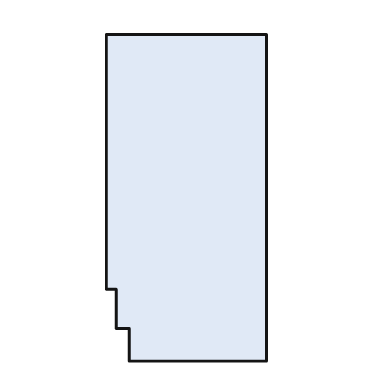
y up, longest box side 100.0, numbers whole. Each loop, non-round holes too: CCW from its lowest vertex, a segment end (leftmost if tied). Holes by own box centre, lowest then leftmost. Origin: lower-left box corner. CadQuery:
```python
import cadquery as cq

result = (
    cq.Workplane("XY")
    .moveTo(7.0, 0.0)
    .lineTo(49.0, 0.0)
    .lineTo(49.0, 100.0)
    .lineTo(0.0, 100.0)
    .lineTo(0.0, 22.0)
    .lineTo(3.0, 22.0)
    .lineTo(3.0, 10.0)
    .lineTo(7.0, 10.0)
    .close()
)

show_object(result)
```